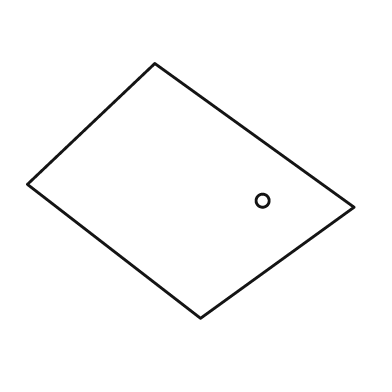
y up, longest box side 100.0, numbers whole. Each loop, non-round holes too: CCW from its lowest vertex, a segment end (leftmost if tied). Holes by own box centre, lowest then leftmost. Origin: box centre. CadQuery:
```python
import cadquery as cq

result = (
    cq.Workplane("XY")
    .moveTo(3.0, -39.0)
    .lineTo(50.0, -5.0)
    .lineTo(-11.0, 39.0)
    .lineTo(-50.0, 2.0)
    .close()
    .moveTo(22.0, -3.0)
    .circle(2.0)
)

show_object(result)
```